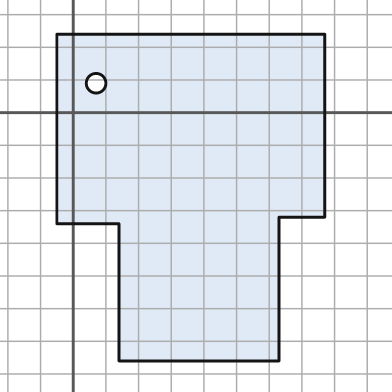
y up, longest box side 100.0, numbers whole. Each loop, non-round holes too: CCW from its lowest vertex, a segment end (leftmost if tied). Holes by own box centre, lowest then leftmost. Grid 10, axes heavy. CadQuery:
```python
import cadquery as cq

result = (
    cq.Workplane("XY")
    .moveTo(14.0, -76.0)
    .lineTo(63.0, -76.0)
    .lineTo(63.0, -32.0)
    .lineTo(77.0, -32.0)
    .lineTo(77.0, 24.0)
    .lineTo(-5.0, 24.0)
    .lineTo(-5.0, -34.0)
    .lineTo(14.0, -34.0)
    .close()
    .moveTo(7.0, 9.0)
    .circle(3.0)
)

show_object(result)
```